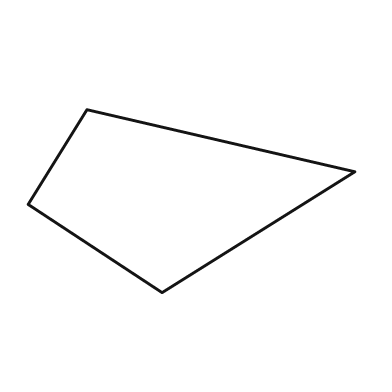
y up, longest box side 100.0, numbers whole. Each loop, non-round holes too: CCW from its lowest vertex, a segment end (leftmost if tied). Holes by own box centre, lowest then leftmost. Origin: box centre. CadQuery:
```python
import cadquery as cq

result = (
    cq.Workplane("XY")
    .moveTo(-9.0, -28.0)
    .lineTo(50.0, 9.0)
    .lineTo(-32.0, 28.0)
    .lineTo(-50.0, -1.0)
    .close()
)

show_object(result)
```